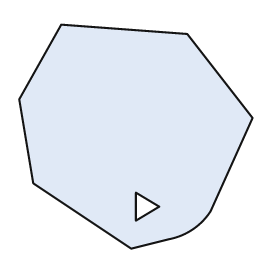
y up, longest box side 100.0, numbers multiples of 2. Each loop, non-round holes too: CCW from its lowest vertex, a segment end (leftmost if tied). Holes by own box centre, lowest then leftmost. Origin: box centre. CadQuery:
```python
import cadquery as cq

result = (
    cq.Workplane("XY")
    .moveTo(-2.0, -48.0)
    .lineTo(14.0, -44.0)
    .threePointArc((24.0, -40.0), (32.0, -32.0))
    .lineTo(50.0, 8.0)
    .lineTo(22.0, 44.0)
    .lineTo(-32.0, 48.0)
    .lineTo(-50.0, 16.0)
    .lineTo(-44.0, -20.0)
    .close()
    .moveTo(0.0, -36.0)
    .lineTo(10.0, -30.0)
    .lineTo(0.0, -24.0)
    .close()
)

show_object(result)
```